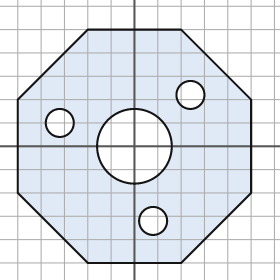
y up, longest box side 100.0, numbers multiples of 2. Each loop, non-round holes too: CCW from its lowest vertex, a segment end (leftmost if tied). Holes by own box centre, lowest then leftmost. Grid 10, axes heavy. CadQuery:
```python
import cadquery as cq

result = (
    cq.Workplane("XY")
    .moveTo(-20.0, -50.0)
    .lineTo(20.0, -50.0)
    .lineTo(50.0, -20.0)
    .lineTo(50.0, 20.0)
    .lineTo(20.0, 50.0)
    .lineTo(-20.0, 50.0)
    .lineTo(-50.0, 20.0)
    .lineTo(-50.0, -20.0)
    .close()
    .moveTo(8.0, -32.0)
    .circle(6.0)
    .moveTo(0.0, 0.0)
    .circle(16.0)
    .moveTo(-32.0, 10.0)
    .circle(6.0)
    .moveTo(24.0, 22.0)
    .circle(6.0)
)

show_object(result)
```